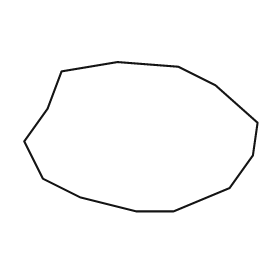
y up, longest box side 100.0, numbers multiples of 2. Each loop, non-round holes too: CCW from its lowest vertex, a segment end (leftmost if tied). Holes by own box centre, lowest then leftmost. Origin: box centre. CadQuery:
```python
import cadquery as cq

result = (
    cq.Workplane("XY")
    .moveTo(-2.0, -32.0)
    .lineTo(14.0, -32.0)
    .lineTo(38.0, -22.0)
    .lineTo(48.0, -8.0)
    .lineTo(50.0, 6.0)
    .lineTo(32.0, 22.0)
    .lineTo(16.0, 30.0)
    .lineTo(-10.0, 32.0)
    .lineTo(-34.0, 28.0)
    .lineTo(-40.0, 12.0)
    .lineTo(-50.0, -2.0)
    .lineTo(-42.0, -18.0)
    .lineTo(-26.0, -26.0)
    .close()
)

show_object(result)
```